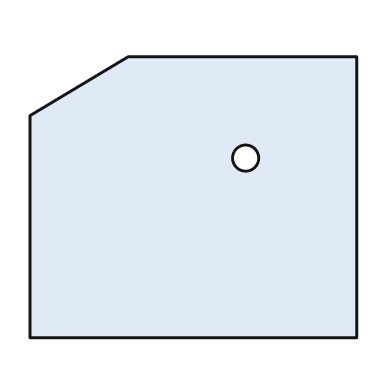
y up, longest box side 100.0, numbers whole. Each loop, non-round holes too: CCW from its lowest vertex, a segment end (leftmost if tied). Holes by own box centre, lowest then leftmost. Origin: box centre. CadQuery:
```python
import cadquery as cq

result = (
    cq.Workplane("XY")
    .moveTo(-50.0, -43.0)
    .lineTo(50.0, -43.0)
    .lineTo(50.0, 43.0)
    .lineTo(-20.0, 43.0)
    .lineTo(-50.0, 25.0)
    .close()
    .moveTo(16.0, 12.0)
    .circle(4.0)
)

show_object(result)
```